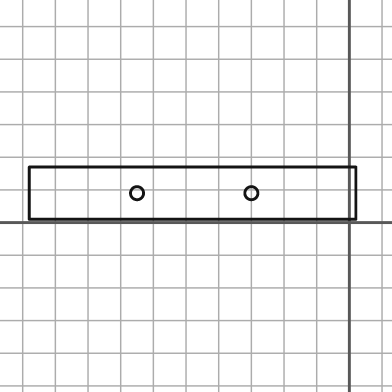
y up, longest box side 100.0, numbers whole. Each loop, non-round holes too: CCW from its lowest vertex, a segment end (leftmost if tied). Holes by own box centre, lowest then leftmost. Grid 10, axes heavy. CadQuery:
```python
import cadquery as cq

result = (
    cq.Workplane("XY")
    .moveTo(-98.0, 1.0)
    .lineTo(2.0, 1.0)
    .lineTo(2.0, 17.0)
    .lineTo(-98.0, 17.0)
    .close()
    .moveTo(-65.0, 9.0)
    .circle(2.0)
    .moveTo(-30.0, 9.0)
    .circle(2.0)
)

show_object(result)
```